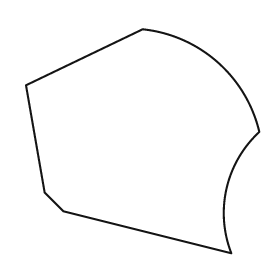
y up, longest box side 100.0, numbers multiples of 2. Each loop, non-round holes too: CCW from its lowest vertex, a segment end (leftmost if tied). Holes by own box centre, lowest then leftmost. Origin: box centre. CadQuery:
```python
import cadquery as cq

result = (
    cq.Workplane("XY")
    .moveTo(38.0, -48.0)
    .threePointArc((36.0, -20.0), (50.0, 4.0))
    .threePointArc((32.0, 34.0), (0.0, 48.0))
    .lineTo(-50.0, 24.0)
    .lineTo(-42.0, -22.0)
    .lineTo(-34.0, -30.0)
    .close()
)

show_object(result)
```